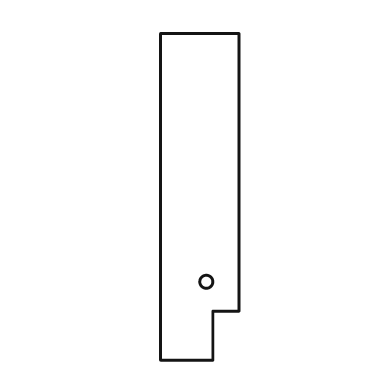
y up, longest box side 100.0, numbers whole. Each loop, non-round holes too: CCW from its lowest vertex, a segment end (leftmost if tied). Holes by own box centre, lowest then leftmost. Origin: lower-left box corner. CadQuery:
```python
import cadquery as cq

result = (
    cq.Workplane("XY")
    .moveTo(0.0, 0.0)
    .lineTo(16.0, 0.0)
    .lineTo(16.0, 15.0)
    .lineTo(24.0, 15.0)
    .lineTo(24.0, 100.0)
    .lineTo(0.0, 100.0)
    .close()
    .moveTo(14.0, 24.0)
    .circle(2.0)
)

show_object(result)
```